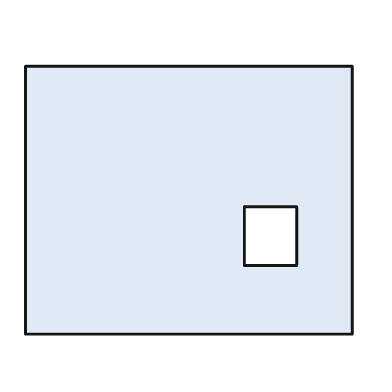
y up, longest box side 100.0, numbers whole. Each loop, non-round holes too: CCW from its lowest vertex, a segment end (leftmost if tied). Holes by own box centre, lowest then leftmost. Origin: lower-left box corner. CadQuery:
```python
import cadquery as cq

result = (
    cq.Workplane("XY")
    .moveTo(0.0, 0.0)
    .lineTo(100.0, 0.0)
    .lineTo(100.0, 82.0)
    .lineTo(0.0, 82.0)
    .close()
    .moveTo(67.0, 21.0)
    .lineTo(83.0, 21.0)
    .lineTo(83.0, 39.0)
    .lineTo(67.0, 39.0)
    .close()
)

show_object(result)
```